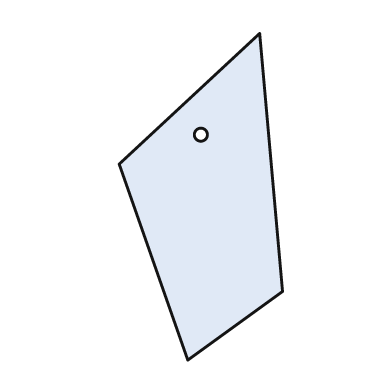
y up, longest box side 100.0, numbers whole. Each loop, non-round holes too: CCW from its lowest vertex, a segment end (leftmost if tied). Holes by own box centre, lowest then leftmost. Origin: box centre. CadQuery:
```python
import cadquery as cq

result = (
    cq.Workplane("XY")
    .moveTo(-4.0, -50.0)
    .lineTo(25.0, -29.0)
    .lineTo(18.0, 50.0)
    .lineTo(-25.0, 10.0)
    .close()
    .moveTo(0.0, 19.0)
    .circle(2.0)
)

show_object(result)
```